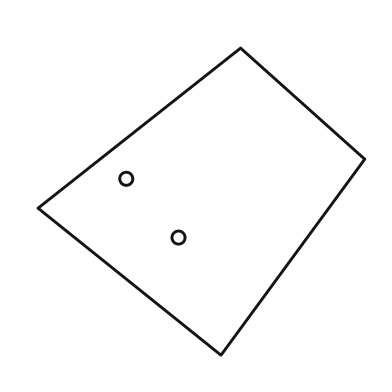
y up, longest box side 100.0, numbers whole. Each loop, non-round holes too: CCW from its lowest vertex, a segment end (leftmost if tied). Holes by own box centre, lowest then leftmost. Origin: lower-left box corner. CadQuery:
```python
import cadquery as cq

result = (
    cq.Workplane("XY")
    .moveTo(56.0, 0.0)
    .lineTo(100.0, 60.0)
    .lineTo(62.0, 94.0)
    .lineTo(0.0, 45.0)
    .close()
    .moveTo(43.0, 36.0)
    .circle(2.0)
    .moveTo(27.0, 54.0)
    .circle(2.0)
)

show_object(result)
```